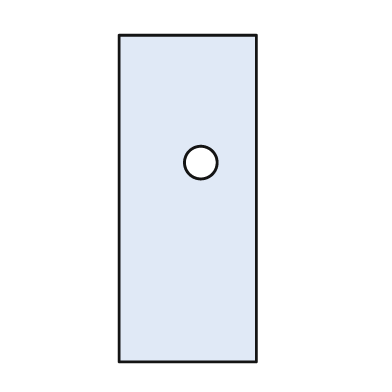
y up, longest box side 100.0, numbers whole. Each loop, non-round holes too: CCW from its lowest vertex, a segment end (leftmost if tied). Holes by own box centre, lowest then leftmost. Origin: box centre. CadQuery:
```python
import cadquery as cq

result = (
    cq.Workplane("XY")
    .moveTo(-21.0, -50.0)
    .lineTo(21.0, -50.0)
    .lineTo(21.0, 50.0)
    .lineTo(-21.0, 50.0)
    .close()
    .moveTo(4.0, 11.0)
    .circle(5.0)
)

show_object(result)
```